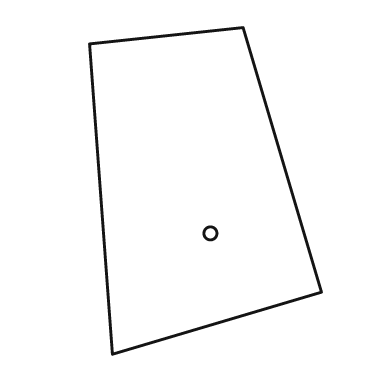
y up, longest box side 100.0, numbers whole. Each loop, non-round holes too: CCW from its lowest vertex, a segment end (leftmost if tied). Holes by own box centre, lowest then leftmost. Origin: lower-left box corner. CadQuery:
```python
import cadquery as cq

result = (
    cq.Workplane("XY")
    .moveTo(7.0, 0.0)
    .lineTo(71.0, 19.0)
    .lineTo(47.0, 100.0)
    .lineTo(0.0, 95.0)
    .close()
    .moveTo(37.0, 37.0)
    .circle(2.0)
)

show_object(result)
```